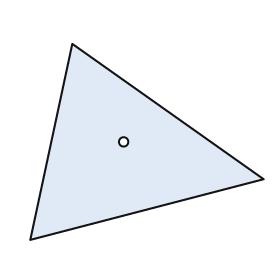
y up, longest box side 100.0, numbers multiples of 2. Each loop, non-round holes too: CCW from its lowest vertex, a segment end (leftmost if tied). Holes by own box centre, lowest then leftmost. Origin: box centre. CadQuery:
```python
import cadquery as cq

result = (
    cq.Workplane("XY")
    .moveTo(-50.0, -42.0)
    .lineTo(50.0, -16.0)
    .lineTo(-32.0, 42.0)
    .close()
    .moveTo(-10.0, 0.0)
    .circle(2.0)
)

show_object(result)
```